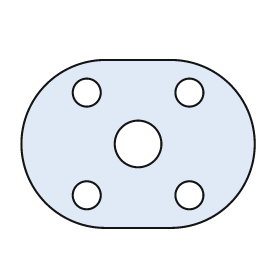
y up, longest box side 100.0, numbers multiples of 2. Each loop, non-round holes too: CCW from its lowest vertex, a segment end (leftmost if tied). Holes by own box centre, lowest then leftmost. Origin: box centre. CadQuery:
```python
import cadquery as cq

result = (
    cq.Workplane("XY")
    .moveTo(-14.0, -36.0)
    .lineTo(14.0, -36.0)
    .threePointArc((50.0, 0.0), (14.0, 36.0))
    .lineTo(-14.0, 36.0)
    .threePointArc((-50.0, 0.0), (-14.0, -36.0))
    .close()
    .moveTo(-22.0, -22.0)
    .circle(6.0)
    .moveTo(22.0, -22.0)
    .circle(6.0)
    .moveTo(0.0, 0.0)
    .circle(10.0)
    .moveTo(-22.0, 22.0)
    .circle(6.0)
    .moveTo(22.0, 22.0)
    .circle(6.0)
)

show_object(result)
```